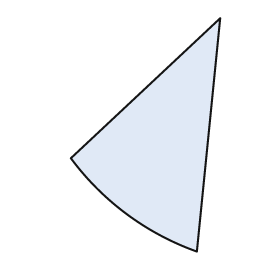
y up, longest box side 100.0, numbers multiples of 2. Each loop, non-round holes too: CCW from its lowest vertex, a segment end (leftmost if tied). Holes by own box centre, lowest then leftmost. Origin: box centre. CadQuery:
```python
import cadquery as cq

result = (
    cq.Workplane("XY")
    .moveTo(22.0, -50.0)
    .lineTo(32.0, 50.0)
    .lineTo(-32.0, -10.0)
    .threePointArc((-8.0, -34.0), (22.0, -50.0))
    .close()
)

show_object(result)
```